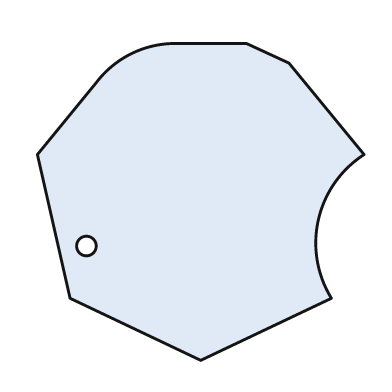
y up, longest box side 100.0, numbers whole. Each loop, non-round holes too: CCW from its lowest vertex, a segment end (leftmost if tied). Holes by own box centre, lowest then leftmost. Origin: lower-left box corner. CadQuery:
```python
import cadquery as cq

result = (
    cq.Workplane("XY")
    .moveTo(50.0, 0.0)
    .lineTo(90.0, 19.0)
    .threePointArc((86.0, 43.0), (100.0, 63.0))
    .lineTo(77.0, 91.0)
    .lineTo(64.0, 97.0)
    .lineTo(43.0, 97.0)
    .threePointArc((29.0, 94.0), (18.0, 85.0))
    .lineTo(0.0, 63.0)
    .lineTo(10.0, 19.0)
    .close()
    .moveTo(15.0, 35.0)
    .circle(3.0)
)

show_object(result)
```